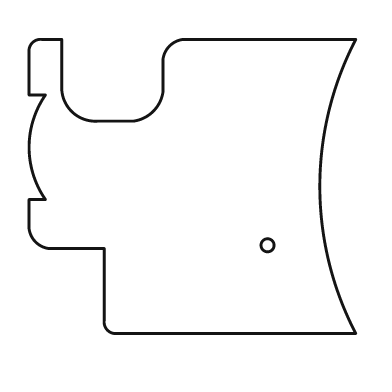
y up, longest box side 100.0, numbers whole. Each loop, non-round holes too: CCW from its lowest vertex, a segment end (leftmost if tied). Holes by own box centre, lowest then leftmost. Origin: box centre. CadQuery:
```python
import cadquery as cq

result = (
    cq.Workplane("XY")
    .moveTo(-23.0, -45.0)
    .lineTo(50.0, -45.0)
    .threePointArc((39.0, 0.0), (50.0, 45.0))
    .lineTo(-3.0, 45.0)
    .threePointArc((-7.0, 43.0), (-9.0, 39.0))
    .lineTo(-9.0, 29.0)
    .threePointArc((-12.0, 23.0), (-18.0, 20.0))
    .lineTo(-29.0, 20.0)
    .threePointArc((-37.0, 23.0), (-40.0, 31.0))
    .lineTo(-40.0, 45.0)
    .lineTo(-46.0, 45.0)
    .threePointArc((-49.0, 44.0), (-50.0, 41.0))
    .lineTo(-50.0, 28.0)
    .lineTo(-45.0, 28.0)
    .threePointArc((-50.0, 12.0), (-45.0, -4.0))
    .lineTo(-50.0, -4.0)
    .lineTo(-50.0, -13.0)
    .threePointArc((-48.0, -17.0), (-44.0, -19.0))
    .lineTo(-27.0, -19.0)
    .lineTo(-27.0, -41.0)
    .threePointArc((-26.0, -44.0), (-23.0, -45.0))
    .close()
    .moveTo(23.0, -18.0)
    .circle(2.0)
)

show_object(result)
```